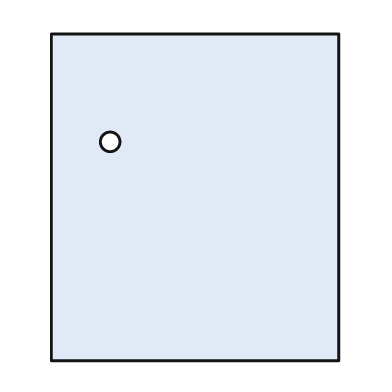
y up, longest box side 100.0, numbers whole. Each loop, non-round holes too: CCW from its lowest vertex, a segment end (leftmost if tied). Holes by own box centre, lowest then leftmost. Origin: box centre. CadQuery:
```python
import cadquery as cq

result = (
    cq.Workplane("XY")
    .moveTo(-44.0, -50.0)
    .lineTo(44.0, -50.0)
    .lineTo(44.0, 50.0)
    .lineTo(-44.0, 50.0)
    .close()
    .moveTo(-26.0, 17.0)
    .circle(3.0)
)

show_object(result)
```